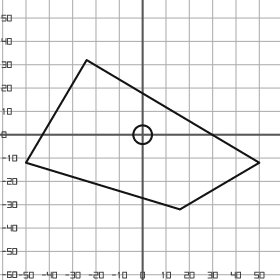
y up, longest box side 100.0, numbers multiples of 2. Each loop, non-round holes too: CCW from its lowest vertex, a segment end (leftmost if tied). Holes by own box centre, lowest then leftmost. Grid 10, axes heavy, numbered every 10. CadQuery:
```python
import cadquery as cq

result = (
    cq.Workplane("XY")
    .moveTo(16.0, -32.0)
    .lineTo(50.0, -12.0)
    .lineTo(-24.0, 32.0)
    .lineTo(-50.0, -12.0)
    .close()
    .moveTo(0.0, 0.0)
    .circle(4.0)
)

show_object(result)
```